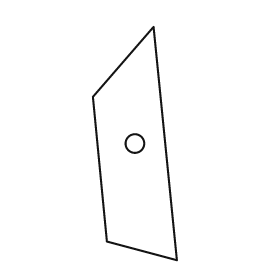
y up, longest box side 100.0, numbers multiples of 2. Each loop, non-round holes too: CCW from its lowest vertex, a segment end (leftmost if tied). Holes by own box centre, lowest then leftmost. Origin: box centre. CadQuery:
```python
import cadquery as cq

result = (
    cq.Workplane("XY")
    .moveTo(18.0, -50.0)
    .lineTo(8.0, 50.0)
    .lineTo(-18.0, 20.0)
    .lineTo(-12.0, -42.0)
    .close()
    .moveTo(0.0, 0.0)
    .circle(4.0)
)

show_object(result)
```